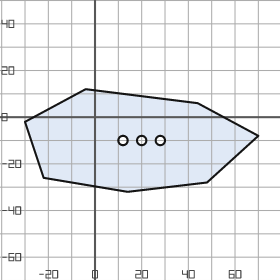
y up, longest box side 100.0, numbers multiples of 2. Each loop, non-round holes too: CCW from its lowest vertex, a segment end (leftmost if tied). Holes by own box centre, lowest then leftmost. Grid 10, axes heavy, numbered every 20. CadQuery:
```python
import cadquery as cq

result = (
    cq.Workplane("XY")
    .moveTo(14.0, -32.0)
    .lineTo(48.0, -28.0)
    .lineTo(70.0, -8.0)
    .lineTo(44.0, 6.0)
    .lineTo(-4.0, 12.0)
    .lineTo(-30.0, -2.0)
    .lineTo(-22.0, -26.0)
    .close()
    .moveTo(12.0, -10.0)
    .circle(2.0)
    .moveTo(20.0, -10.0)
    .circle(2.0)
    .moveTo(28.0, -10.0)
    .circle(2.0)
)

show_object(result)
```